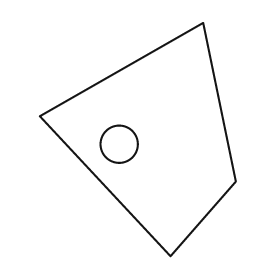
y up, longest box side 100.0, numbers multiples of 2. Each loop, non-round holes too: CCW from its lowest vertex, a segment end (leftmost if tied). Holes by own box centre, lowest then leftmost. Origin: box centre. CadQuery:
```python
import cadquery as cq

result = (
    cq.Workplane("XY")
    .moveTo(14.0, -50.0)
    .lineTo(42.0, -18.0)
    .lineTo(28.0, 50.0)
    .lineTo(-42.0, 10.0)
    .close()
    .moveTo(-8.0, -2.0)
    .circle(8.0)
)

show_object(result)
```